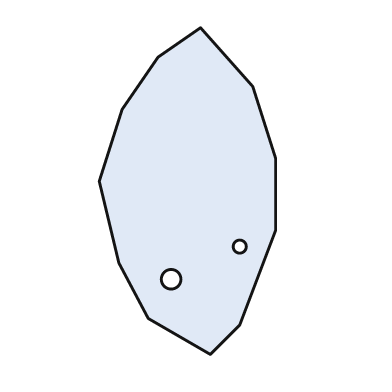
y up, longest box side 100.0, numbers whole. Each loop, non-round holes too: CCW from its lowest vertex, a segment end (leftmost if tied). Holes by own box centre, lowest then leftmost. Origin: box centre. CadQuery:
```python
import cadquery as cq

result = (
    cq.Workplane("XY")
    .moveTo(7.0, -50.0)
    .lineTo(16.0, -41.0)
    .lineTo(27.0, -12.0)
    .lineTo(27.0, 10.0)
    .lineTo(20.0, 32.0)
    .lineTo(4.0, 50.0)
    .lineTo(-9.0, 41.0)
    .lineTo(-20.0, 25.0)
    .lineTo(-27.0, 3.0)
    .lineTo(-21.0, -22.0)
    .lineTo(-12.0, -39.0)
    .close()
    .moveTo(-5.0, -27.0)
    .circle(3.0)
    .moveTo(16.0, -17.0)
    .circle(2.0)
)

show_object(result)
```